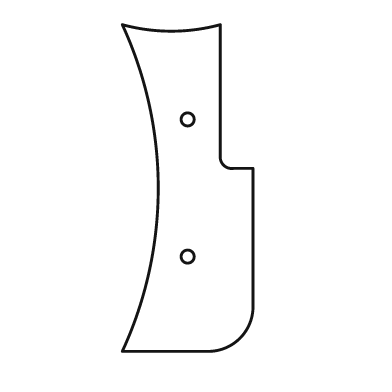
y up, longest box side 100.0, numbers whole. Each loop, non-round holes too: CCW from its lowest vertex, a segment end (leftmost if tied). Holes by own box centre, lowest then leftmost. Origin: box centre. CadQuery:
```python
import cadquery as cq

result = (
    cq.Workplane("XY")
    .moveTo(-20.0, -50.0)
    .lineTo(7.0, -50.0)
    .threePointArc((16.0, -46.0), (20.0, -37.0))
    .lineTo(20.0, 6.0)
    .lineTo(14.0, 6.0)
    .threePointArc((11.0, 7.0), (10.0, 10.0))
    .lineTo(10.0, 50.0)
    .threePointArc((-5.0, 48.0), (-20.0, 50.0))
    .threePointArc((-9.0, 0.0), (-20.0, -50.0))
    .close()
    .moveTo(0.0, -21.0)
    .circle(2.0)
    .moveTo(0.0, 21.0)
    .circle(2.0)
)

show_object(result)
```